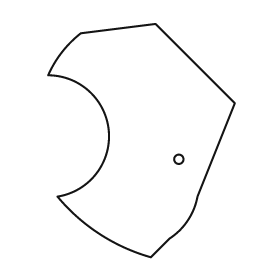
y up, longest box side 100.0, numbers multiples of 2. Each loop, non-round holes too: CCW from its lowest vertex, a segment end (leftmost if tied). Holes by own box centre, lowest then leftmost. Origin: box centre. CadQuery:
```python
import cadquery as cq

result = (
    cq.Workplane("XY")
    .moveTo(4.0, -50.0)
    .lineTo(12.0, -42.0)
    .threePointArc((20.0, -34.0), (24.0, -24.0))
    .lineTo(40.0, 16.0)
    .lineTo(6.0, 50.0)
    .lineTo(-26.0, 46.0)
    .threePointArc((-34.0, 38.0), (-40.0, 28.0))
    .threePointArc((-14.0, 4.0), (-36.0, -24.0))
    .threePointArc((-18.0, -40.0), (4.0, -50.0))
    .close()
    .moveTo(16.0, -8.0)
    .circle(2.0)
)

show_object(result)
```